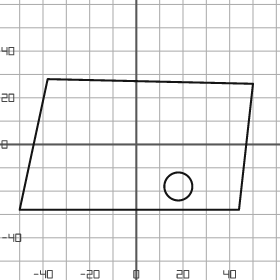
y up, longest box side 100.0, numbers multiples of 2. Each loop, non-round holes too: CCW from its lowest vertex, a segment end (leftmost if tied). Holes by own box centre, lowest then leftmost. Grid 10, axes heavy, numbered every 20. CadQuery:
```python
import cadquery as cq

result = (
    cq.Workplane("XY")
    .moveTo(-50.0, -28.0)
    .lineTo(44.0, -28.0)
    .lineTo(50.0, 26.0)
    .lineTo(-38.0, 28.0)
    .close()
    .moveTo(18.0, -18.0)
    .circle(6.0)
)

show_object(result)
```